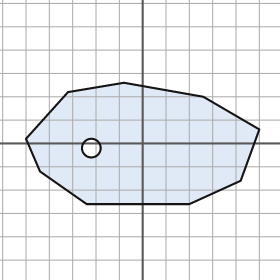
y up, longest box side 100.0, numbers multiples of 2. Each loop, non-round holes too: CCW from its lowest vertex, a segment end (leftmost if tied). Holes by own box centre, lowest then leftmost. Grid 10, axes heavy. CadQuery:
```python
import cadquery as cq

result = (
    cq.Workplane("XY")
    .moveTo(-24.0, -26.0)
    .lineTo(20.0, -26.0)
    .lineTo(42.0, -16.0)
    .lineTo(50.0, 6.0)
    .lineTo(26.0, 20.0)
    .lineTo(-8.0, 26.0)
    .lineTo(-32.0, 22.0)
    .lineTo(-50.0, 2.0)
    .lineTo(-44.0, -12.0)
    .close()
    .moveTo(-22.0, -2.0)
    .circle(4.0)
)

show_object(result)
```